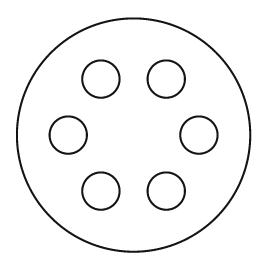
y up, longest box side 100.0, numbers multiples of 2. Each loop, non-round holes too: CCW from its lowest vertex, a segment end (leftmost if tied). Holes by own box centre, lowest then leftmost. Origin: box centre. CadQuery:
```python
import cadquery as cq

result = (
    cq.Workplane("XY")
    .moveTo(0.0, 0.0)
    .circle(50.0)
    .moveTo(-14.0, -24.0)
    .circle(8.0)
    .moveTo(14.0, -24.0)
    .circle(8.0)
    .moveTo(-28.0, 0.0)
    .circle(8.0)
    .moveTo(28.0, 0.0)
    .circle(8.0)
    .moveTo(-14.0, 24.0)
    .circle(8.0)
    .moveTo(14.0, 24.0)
    .circle(8.0)
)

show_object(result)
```